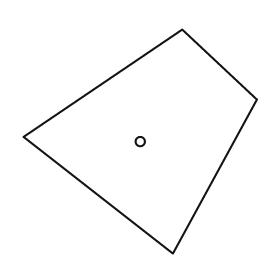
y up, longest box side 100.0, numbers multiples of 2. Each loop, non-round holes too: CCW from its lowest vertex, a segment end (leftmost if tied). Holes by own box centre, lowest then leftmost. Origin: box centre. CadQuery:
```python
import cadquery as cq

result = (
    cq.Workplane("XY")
    .moveTo(14.0, -48.0)
    .lineTo(50.0, 18.0)
    .lineTo(18.0, 48.0)
    .lineTo(-50.0, 2.0)
    .close()
    .moveTo(0.0, 0.0)
    .circle(2.0)
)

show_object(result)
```